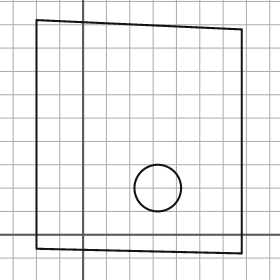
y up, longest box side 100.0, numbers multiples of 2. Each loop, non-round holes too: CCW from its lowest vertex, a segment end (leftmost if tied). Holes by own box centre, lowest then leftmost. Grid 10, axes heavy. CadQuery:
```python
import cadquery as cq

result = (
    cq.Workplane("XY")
    .moveTo(68.0, -8.0)
    .lineTo(68.0, 88.0)
    .lineTo(-20.0, 92.0)
    .lineTo(-20.0, -6.0)
    .close()
    .moveTo(32.0, 20.0)
    .circle(10.0)
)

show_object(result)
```